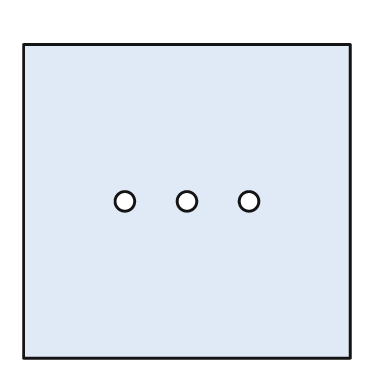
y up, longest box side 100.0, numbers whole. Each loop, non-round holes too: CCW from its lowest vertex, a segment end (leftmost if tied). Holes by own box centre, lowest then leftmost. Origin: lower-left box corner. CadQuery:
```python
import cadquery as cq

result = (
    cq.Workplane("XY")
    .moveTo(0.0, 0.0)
    .lineTo(100.0, 0.0)
    .lineTo(100.0, 96.0)
    .lineTo(0.0, 96.0)
    .close()
    .moveTo(31.0, 48.0)
    .circle(3.0)
    .moveTo(50.0, 48.0)
    .circle(3.0)
    .moveTo(69.0, 48.0)
    .circle(3.0)
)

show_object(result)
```